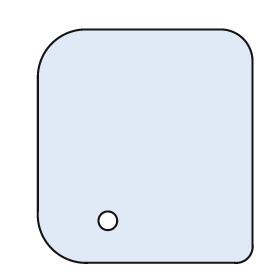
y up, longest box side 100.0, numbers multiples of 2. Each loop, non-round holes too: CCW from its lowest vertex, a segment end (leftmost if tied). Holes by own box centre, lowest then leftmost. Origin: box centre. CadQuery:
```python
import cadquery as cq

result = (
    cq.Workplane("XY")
    .moveTo(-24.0, -50.0)
    .lineTo(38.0, -50.0)
    .threePointArc((44.0, -48.0), (46.0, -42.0))
    .lineTo(46.0, 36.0)
    .threePointArc((42.0, 46.0), (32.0, 50.0))
    .lineTo(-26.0, 50.0)
    .threePointArc((-40.0, 44.0), (-46.0, 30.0))
    .lineTo(-46.0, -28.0)
    .threePointArc((-40.0, -44.0), (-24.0, -50.0))
    .close()
    .moveTo(-16.0, -32.0)
    .circle(4.0)
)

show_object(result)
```